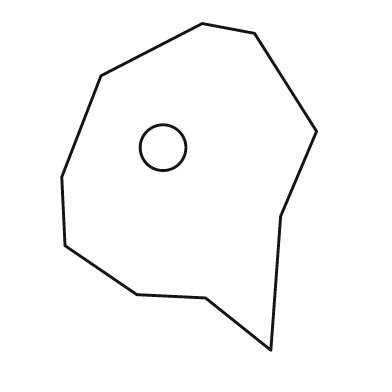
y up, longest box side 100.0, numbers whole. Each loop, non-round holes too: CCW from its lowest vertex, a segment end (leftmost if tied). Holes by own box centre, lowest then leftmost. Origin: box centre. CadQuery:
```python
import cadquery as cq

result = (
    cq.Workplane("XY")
    .moveTo(25.0, -50.0)
    .lineTo(28.0, -9.0)
    .lineTo(39.0, 17.0)
    .lineTo(20.0, 47.0)
    .lineTo(4.0, 50.0)
    .lineTo(-27.0, 34.0)
    .lineTo(-39.0, 3.0)
    .lineTo(-38.0, -18.0)
    .lineTo(-16.0, -33.0)
    .lineTo(5.0, -34.0)
    .close()
    .moveTo(-8.0, 12.0)
    .circle(7.0)
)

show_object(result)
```